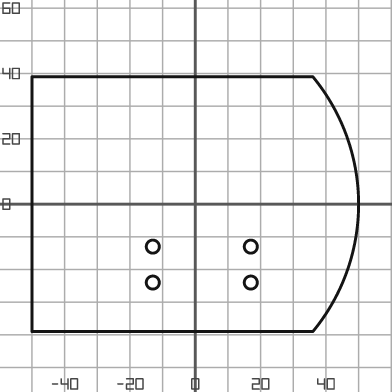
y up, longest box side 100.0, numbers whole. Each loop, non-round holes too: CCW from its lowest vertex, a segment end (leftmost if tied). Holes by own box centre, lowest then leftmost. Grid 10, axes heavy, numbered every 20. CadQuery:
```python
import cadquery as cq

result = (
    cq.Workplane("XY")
    .moveTo(-50.0, -39.0)
    .lineTo(36.0, -39.0)
    .threePointArc((50.0, 0.0), (36.0, 39.0))
    .lineTo(-50.0, 39.0)
    .close()
    .moveTo(-13.0, -24.0)
    .circle(2.0)
    .moveTo(17.0, -24.0)
    .circle(2.0)
    .moveTo(-13.0, -13.0)
    .circle(2.0)
    .moveTo(17.0, -13.0)
    .circle(2.0)
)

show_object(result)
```